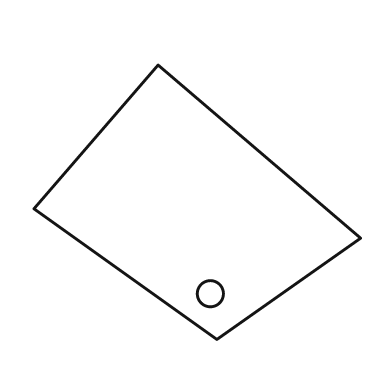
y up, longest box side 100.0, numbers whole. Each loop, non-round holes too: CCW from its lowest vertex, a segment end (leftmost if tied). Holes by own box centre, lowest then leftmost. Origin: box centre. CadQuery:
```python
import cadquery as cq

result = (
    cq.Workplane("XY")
    .moveTo(6.0, -42.0)
    .lineTo(50.0, -11.0)
    .lineTo(-12.0, 42.0)
    .lineTo(-50.0, -2.0)
    .close()
    .moveTo(4.0, -28.0)
    .circle(4.0)
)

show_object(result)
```